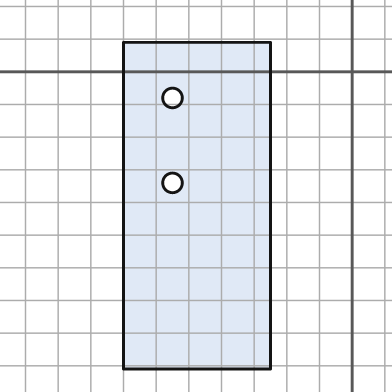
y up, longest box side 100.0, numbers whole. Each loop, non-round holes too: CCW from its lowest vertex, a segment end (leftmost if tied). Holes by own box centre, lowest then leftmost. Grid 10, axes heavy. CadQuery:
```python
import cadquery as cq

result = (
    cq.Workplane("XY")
    .moveTo(-70.0, -91.0)
    .lineTo(-25.0, -91.0)
    .lineTo(-25.0, 9.0)
    .lineTo(-70.0, 9.0)
    .close()
    .moveTo(-55.0, -34.0)
    .circle(3.0)
    .moveTo(-55.0, -8.0)
    .circle(3.0)
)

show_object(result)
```